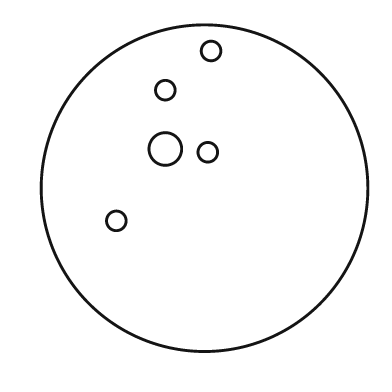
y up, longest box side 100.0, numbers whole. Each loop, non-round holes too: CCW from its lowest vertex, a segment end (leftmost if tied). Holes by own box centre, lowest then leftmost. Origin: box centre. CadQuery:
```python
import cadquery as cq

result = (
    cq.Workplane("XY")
    .moveTo(0.0, 0.0)
    .circle(50.0)
    .moveTo(-27.0, -10.0)
    .circle(3.0)
    .moveTo(1.0, 11.0)
    .circle(3.0)
    .moveTo(-12.0, 12.0)
    .circle(5.0)
    .moveTo(-12.0, 30.0)
    .circle(3.0)
    .moveTo(2.0, 42.0)
    .circle(3.0)
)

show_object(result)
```